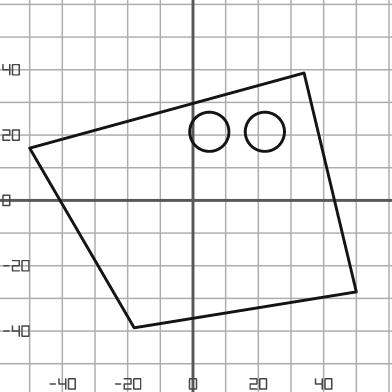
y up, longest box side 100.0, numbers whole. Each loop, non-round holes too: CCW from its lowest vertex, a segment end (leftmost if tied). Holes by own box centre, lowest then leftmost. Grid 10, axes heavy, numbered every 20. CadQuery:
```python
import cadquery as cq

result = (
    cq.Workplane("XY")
    .moveTo(-18.0, -39.0)
    .lineTo(50.0, -28.0)
    .lineTo(34.0, 39.0)
    .lineTo(-50.0, 16.0)
    .close()
    .moveTo(5.0, 21.0)
    .circle(6.0)
    .moveTo(22.0, 21.0)
    .circle(6.0)
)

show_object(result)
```